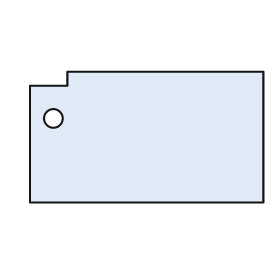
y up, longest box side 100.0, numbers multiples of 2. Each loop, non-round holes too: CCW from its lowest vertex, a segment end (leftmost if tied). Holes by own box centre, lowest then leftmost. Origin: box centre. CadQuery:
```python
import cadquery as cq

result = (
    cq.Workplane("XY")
    .moveTo(-50.0, -28.0)
    .lineTo(50.0, -28.0)
    .lineTo(50.0, 28.0)
    .lineTo(-34.0, 28.0)
    .lineTo(-34.0, 22.0)
    .lineTo(-50.0, 22.0)
    .close()
    .moveTo(-40.0, 8.0)
    .circle(4.0)
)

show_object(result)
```